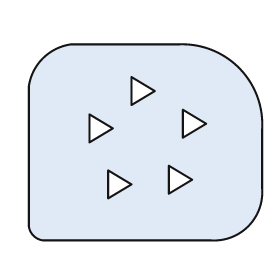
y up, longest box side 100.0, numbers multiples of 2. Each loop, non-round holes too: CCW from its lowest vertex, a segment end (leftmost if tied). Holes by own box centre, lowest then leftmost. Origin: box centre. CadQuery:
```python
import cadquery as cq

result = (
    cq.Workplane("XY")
    .moveTo(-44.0, -42.0)
    .lineTo(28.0, -42.0)
    .threePointArc((44.0, -36.0), (50.0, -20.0))
    .lineTo(50.0, 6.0)
    .threePointArc((40.0, 32.0), (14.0, 42.0))
    .lineTo(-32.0, 42.0)
    .threePointArc((-44.0, 36.0), (-50.0, 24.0))
    .lineTo(-50.0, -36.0)
    .threePointArc((-48.0, -40.0), (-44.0, -42.0))
    .close()
    .moveTo(-16.0, -24.0)
    .lineTo(-6.0, -18.0)
    .lineTo(-16.0, -12.0)
    .close()
    .moveTo(10.0, -22.0)
    .lineTo(20.0, -16.0)
    .lineTo(10.0, -10.0)
    .close()
    .moveTo(-24.0, 0.0)
    .lineTo(-14.0, 6.0)
    .lineTo(-24.0, 12.0)
    .close()
    .moveTo(16.0, 2.0)
    .lineTo(26.0, 8.0)
    .lineTo(16.0, 14.0)
    .close()
    .moveTo(-6.0, 16.0)
    .lineTo(4.0, 22.0)
    .lineTo(-6.0, 28.0)
    .close()
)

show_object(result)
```